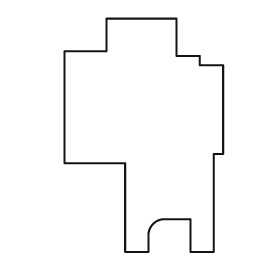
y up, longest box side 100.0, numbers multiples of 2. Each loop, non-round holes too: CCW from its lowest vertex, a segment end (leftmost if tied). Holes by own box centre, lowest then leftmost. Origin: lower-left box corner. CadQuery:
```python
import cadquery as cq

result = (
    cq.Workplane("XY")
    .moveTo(26.0, 0.0)
    .lineTo(36.0, 0.0)
    .lineTo(36.0, 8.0)
    .threePointArc((38.0, 12.0), (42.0, 14.0))
    .lineTo(54.0, 14.0)
    .lineTo(54.0, 0.0)
    .lineTo(64.0, 0.0)
    .lineTo(64.0, 42.0)
    .lineTo(68.0, 42.0)
    .lineTo(68.0, 80.0)
    .lineTo(58.0, 80.0)
    .lineTo(58.0, 84.0)
    .lineTo(48.0, 84.0)
    .lineTo(48.0, 100.0)
    .lineTo(18.0, 100.0)
    .lineTo(18.0, 86.0)
    .lineTo(0.0, 86.0)
    .lineTo(0.0, 38.0)
    .lineTo(26.0, 38.0)
    .close()
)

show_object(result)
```